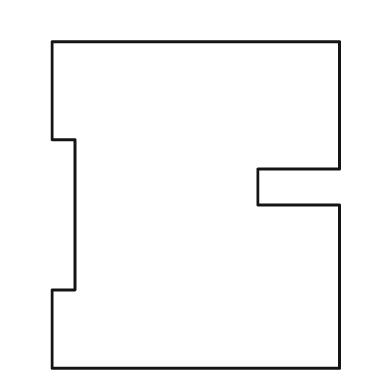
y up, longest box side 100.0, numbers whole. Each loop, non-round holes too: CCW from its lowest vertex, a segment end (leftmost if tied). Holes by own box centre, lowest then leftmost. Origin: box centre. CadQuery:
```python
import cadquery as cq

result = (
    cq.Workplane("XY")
    .moveTo(-44.0, -50.0)
    .lineTo(44.0, -50.0)
    .lineTo(44.0, 0.0)
    .lineTo(19.0, 0.0)
    .lineTo(19.0, 11.0)
    .lineTo(44.0, 11.0)
    .lineTo(44.0, 50.0)
    .lineTo(-44.0, 50.0)
    .lineTo(-44.0, 20.0)
    .lineTo(-37.0, 20.0)
    .lineTo(-37.0, -26.0)
    .lineTo(-44.0, -26.0)
    .close()
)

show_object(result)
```